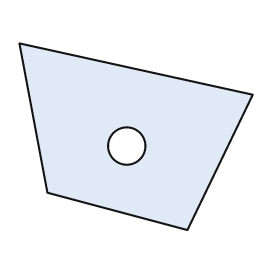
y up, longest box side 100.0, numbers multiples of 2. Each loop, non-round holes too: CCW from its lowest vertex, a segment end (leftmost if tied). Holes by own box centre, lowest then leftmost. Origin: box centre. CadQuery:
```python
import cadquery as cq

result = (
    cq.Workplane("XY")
    .moveTo(22.0, -40.0)
    .lineTo(50.0, 18.0)
    .lineTo(-50.0, 40.0)
    .lineTo(-38.0, -24.0)
    .close()
    .moveTo(-4.0, -4.0)
    .circle(8.0)
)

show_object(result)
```